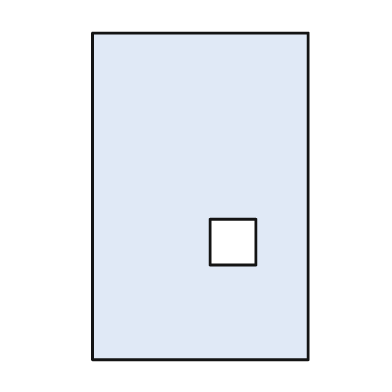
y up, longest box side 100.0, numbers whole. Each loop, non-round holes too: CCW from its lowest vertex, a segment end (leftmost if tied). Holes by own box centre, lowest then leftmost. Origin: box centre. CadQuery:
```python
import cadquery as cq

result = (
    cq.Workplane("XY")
    .moveTo(-33.0, -50.0)
    .lineTo(33.0, -50.0)
    .lineTo(33.0, 50.0)
    .lineTo(-33.0, 50.0)
    .close()
    .moveTo(3.0, -21.0)
    .lineTo(17.0, -21.0)
    .lineTo(17.0, -7.0)
    .lineTo(3.0, -7.0)
    .close()
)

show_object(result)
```